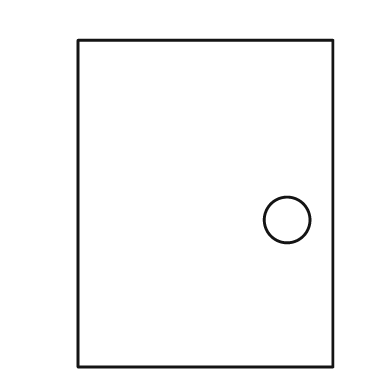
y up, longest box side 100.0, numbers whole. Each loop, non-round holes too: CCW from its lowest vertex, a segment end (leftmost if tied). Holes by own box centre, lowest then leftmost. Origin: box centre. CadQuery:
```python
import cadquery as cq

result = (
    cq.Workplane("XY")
    .moveTo(-39.0, -50.0)
    .lineTo(39.0, -50.0)
    .lineTo(39.0, 50.0)
    .lineTo(-39.0, 50.0)
    .close()
    .moveTo(25.0, -5.0)
    .circle(7.0)
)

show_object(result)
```